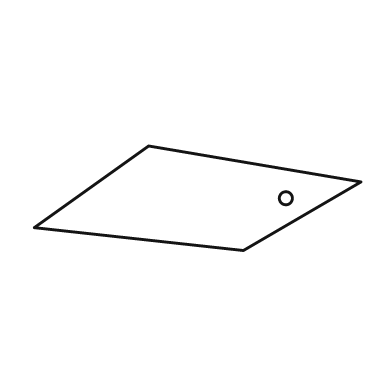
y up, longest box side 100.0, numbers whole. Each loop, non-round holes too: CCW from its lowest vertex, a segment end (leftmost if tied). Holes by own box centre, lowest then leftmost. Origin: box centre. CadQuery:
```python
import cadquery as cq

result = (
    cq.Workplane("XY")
    .moveTo(14.0, -16.0)
    .lineTo(50.0, 5.0)
    .lineTo(-15.0, 16.0)
    .lineTo(-50.0, -9.0)
    .close()
    .moveTo(27.0, 0.0)
    .circle(2.0)
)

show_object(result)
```